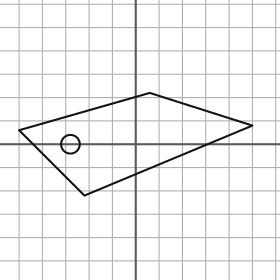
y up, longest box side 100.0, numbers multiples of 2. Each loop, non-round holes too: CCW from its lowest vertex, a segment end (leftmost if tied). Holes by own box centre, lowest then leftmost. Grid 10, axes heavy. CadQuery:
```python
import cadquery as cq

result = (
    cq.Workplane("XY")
    .moveTo(-22.0, -22.0)
    .lineTo(50.0, 8.0)
    .lineTo(6.0, 22.0)
    .lineTo(-50.0, 6.0)
    .close()
    .moveTo(-28.0, 0.0)
    .circle(4.0)
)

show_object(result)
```